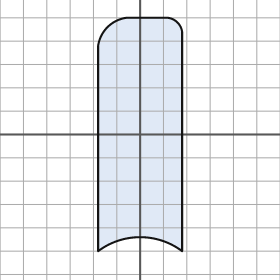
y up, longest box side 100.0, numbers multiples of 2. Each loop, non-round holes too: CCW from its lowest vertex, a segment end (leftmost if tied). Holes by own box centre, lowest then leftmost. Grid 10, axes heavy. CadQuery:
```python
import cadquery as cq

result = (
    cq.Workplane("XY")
    .moveTo(-18.0, -50.0)
    .threePointArc((0.0, -44.0), (18.0, -50.0))
    .lineTo(18.0, 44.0)
    .threePointArc((16.0, 48.0), (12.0, 50.0))
    .lineTo(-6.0, 50.0)
    .threePointArc((-14.0, 46.0), (-18.0, 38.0))
    .close()
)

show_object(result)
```